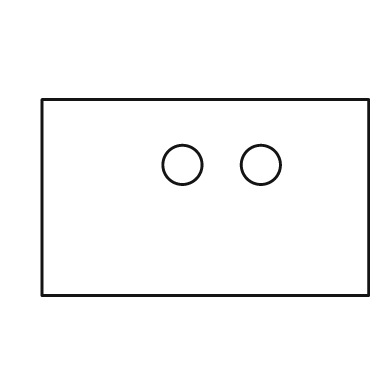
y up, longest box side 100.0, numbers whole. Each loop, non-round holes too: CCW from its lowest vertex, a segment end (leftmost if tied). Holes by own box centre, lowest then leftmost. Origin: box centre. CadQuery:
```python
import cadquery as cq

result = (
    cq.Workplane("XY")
    .moveTo(-50.0, -30.0)
    .lineTo(50.0, -30.0)
    .lineTo(50.0, 30.0)
    .lineTo(-50.0, 30.0)
    .close()
    .moveTo(-7.0, 10.0)
    .circle(6.0)
    .moveTo(17.0, 10.0)
    .circle(6.0)
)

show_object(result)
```